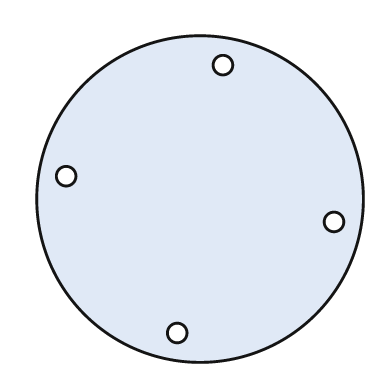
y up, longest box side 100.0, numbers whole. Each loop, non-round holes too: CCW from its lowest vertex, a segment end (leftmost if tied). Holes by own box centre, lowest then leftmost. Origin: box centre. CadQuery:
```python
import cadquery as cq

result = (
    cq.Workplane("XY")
    .moveTo(0.0, 0.0)
    .circle(50.0)
    .moveTo(-7.0, -41.0)
    .circle(3.0)
    .moveTo(41.0, -7.0)
    .circle(3.0)
    .moveTo(-41.0, 7.0)
    .circle(3.0)
    .moveTo(7.0, 41.0)
    .circle(3.0)
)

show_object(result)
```